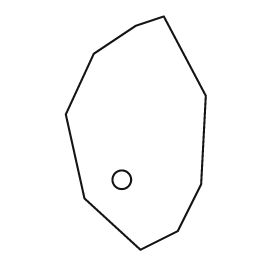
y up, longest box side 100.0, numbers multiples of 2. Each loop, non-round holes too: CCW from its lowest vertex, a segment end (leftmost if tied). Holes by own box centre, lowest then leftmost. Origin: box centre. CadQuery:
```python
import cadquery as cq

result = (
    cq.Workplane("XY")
    .moveTo(2.0, -50.0)
    .lineTo(18.0, -42.0)
    .lineTo(28.0, -22.0)
    .lineTo(30.0, 16.0)
    .lineTo(12.0, 50.0)
    .lineTo(0.0, 46.0)
    .lineTo(-18.0, 34.0)
    .lineTo(-30.0, 8.0)
    .lineTo(-22.0, -28.0)
    .close()
    .moveTo(-6.0, -20.0)
    .circle(4.0)
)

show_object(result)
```